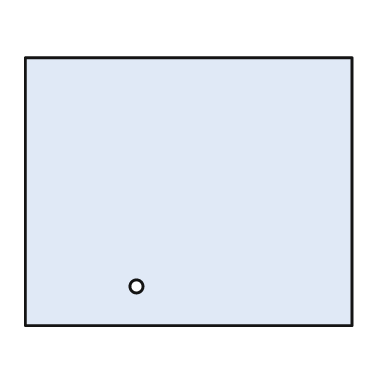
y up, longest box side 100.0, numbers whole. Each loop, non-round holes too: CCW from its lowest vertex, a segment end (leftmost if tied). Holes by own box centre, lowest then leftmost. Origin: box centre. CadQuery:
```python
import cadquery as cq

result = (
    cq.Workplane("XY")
    .moveTo(-50.0, -41.0)
    .lineTo(50.0, -41.0)
    .lineTo(50.0, 41.0)
    .lineTo(-50.0, 41.0)
    .close()
    .moveTo(-16.0, -29.0)
    .circle(2.0)
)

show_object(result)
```